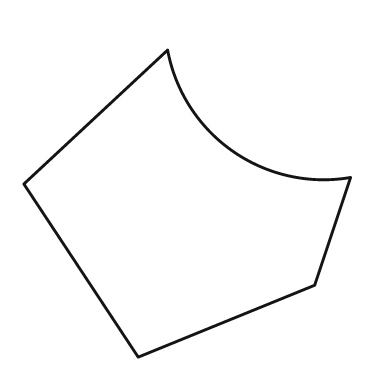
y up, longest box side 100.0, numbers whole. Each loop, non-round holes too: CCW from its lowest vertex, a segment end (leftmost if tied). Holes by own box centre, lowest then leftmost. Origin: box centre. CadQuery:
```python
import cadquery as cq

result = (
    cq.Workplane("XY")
    .moveTo(-15.0, -47.0)
    .lineTo(39.0, -25.0)
    .lineTo(50.0, 8.0)
    .threePointArc((14.0, 16.0), (-6.0, 47.0))
    .lineTo(-50.0, 6.0)
    .close()
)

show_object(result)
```